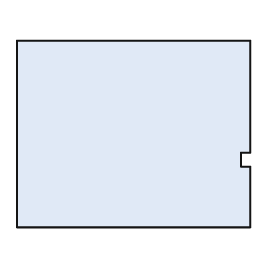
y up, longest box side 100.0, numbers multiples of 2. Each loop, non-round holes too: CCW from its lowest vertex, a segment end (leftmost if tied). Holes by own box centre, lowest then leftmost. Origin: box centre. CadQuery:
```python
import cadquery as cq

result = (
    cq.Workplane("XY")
    .moveTo(-50.0, -40.0)
    .lineTo(50.0, -40.0)
    .lineTo(50.0, -14.0)
    .lineTo(46.0, -14.0)
    .lineTo(46.0, -8.0)
    .lineTo(50.0, -8.0)
    .lineTo(50.0, 40.0)
    .lineTo(-50.0, 40.0)
    .close()
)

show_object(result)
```